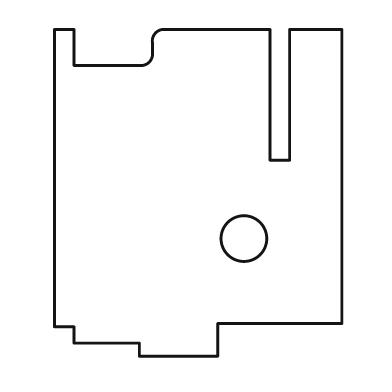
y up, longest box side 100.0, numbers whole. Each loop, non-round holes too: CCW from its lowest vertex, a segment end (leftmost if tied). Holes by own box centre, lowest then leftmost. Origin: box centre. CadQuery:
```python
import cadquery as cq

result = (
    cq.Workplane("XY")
    .moveTo(-18.0, -50.0)
    .lineTo(6.0, -50.0)
    .lineTo(6.0, -40.0)
    .lineTo(44.0, -40.0)
    .lineTo(44.0, 50.0)
    .lineTo(28.0, 50.0)
    .lineTo(28.0, 10.0)
    .lineTo(22.0, 10.0)
    .lineTo(22.0, 50.0)
    .lineTo(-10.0, 50.0)
    .threePointArc((-13.0, 49.0), (-14.0, 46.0))
    .lineTo(-14.0, 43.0)
    .threePointArc((-15.0, 40.0), (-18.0, 39.0))
    .lineTo(-38.0, 39.0)
    .lineTo(-38.0, 50.0)
    .lineTo(-44.0, 50.0)
    .lineTo(-44.0, -41.0)
    .lineTo(-38.0, -41.0)
    .lineTo(-38.0, -46.0)
    .lineTo(-18.0, -46.0)
    .close()
    .moveTo(14.0, -14.0)
    .circle(7.0)
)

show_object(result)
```